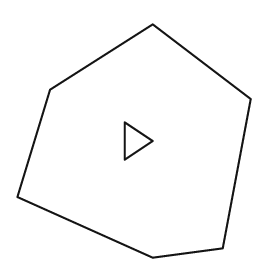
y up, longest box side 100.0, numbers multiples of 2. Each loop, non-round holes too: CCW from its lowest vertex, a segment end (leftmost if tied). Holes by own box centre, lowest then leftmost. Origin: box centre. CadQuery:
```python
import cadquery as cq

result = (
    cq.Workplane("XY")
    .moveTo(8.0, -50.0)
    .lineTo(38.0, -46.0)
    .lineTo(50.0, 18.0)
    .lineTo(8.0, 50.0)
    .lineTo(-36.0, 22.0)
    .lineTo(-50.0, -24.0)
    .close()
    .moveTo(-4.0, -8.0)
    .lineTo(8.0, 0.0)
    .lineTo(-4.0, 8.0)
    .close()
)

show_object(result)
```